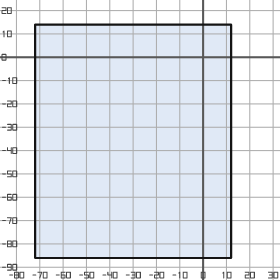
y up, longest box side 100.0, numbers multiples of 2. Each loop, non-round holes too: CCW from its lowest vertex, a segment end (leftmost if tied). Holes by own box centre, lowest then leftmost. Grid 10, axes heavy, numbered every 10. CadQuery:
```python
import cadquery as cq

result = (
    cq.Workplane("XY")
    .moveTo(-72.0, -86.0)
    .lineTo(12.0, -86.0)
    .lineTo(12.0, 14.0)
    .lineTo(-72.0, 14.0)
    .close()
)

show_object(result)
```